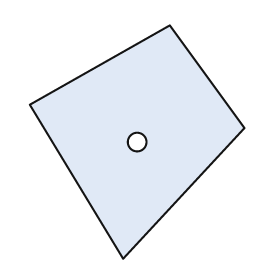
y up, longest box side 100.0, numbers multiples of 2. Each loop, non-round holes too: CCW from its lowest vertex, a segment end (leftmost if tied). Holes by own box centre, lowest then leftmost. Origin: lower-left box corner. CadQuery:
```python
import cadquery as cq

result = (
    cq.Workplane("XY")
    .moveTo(40.0, 0.0)
    .lineTo(92.0, 56.0)
    .lineTo(60.0, 100.0)
    .lineTo(0.0, 66.0)
    .close()
    .moveTo(46.0, 50.0)
    .circle(4.0)
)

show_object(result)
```